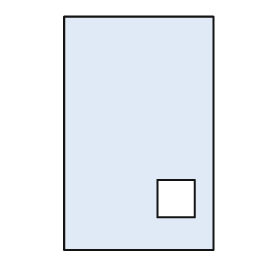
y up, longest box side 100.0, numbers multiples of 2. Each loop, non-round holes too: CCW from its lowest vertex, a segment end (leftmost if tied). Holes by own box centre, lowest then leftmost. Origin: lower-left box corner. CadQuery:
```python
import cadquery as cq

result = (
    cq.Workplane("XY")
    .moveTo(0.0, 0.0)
    .lineTo(64.0, 0.0)
    .lineTo(64.0, 100.0)
    .lineTo(0.0, 100.0)
    .close()
    .moveTo(40.0, 14.0)
    .lineTo(56.0, 14.0)
    .lineTo(56.0, 30.0)
    .lineTo(40.0, 30.0)
    .close()
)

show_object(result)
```